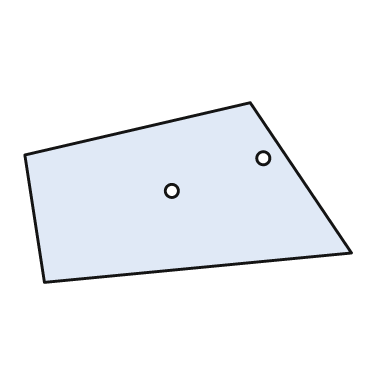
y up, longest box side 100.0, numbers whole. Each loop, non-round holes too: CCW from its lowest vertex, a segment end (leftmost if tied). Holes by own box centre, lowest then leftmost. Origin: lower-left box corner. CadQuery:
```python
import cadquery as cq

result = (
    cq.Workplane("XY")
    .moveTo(6.0, 0.0)
    .lineTo(100.0, 9.0)
    .lineTo(69.0, 55.0)
    .lineTo(0.0, 39.0)
    .close()
    .moveTo(45.0, 28.0)
    .circle(2.0)
    .moveTo(73.0, 38.0)
    .circle(2.0)
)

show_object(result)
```